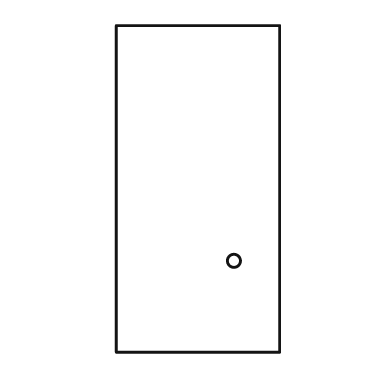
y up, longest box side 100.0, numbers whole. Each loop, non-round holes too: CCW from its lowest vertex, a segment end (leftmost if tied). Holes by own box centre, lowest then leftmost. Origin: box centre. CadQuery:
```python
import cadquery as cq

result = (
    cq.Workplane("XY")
    .moveTo(-25.0, -50.0)
    .lineTo(25.0, -50.0)
    .lineTo(25.0, 50.0)
    .lineTo(-25.0, 50.0)
    .close()
    .moveTo(11.0, -22.0)
    .circle(2.0)
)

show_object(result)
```